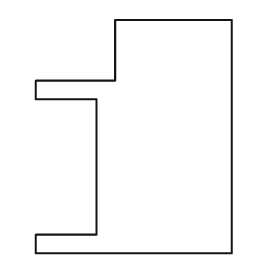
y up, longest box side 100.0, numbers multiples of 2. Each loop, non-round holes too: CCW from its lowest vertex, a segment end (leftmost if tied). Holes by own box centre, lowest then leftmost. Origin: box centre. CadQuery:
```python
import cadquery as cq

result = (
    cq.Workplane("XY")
    .moveTo(-42.0, -50.0)
    .lineTo(42.0, -50.0)
    .lineTo(42.0, 50.0)
    .lineTo(-8.0, 50.0)
    .lineTo(-8.0, 24.0)
    .lineTo(-42.0, 24.0)
    .lineTo(-42.0, 16.0)
    .lineTo(-16.0, 16.0)
    .lineTo(-16.0, -42.0)
    .lineTo(-42.0, -42.0)
    .close()
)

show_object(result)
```